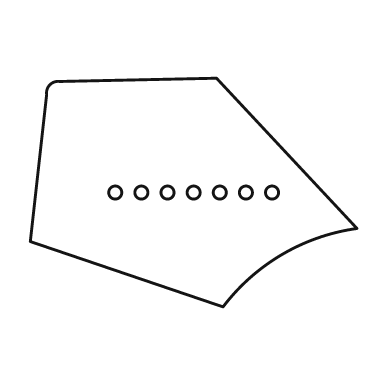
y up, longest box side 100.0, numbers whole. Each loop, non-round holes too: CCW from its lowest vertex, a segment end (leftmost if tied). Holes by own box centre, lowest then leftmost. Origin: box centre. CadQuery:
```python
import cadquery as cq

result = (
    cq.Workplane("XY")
    .moveTo(9.0, -35.0)
    .threePointArc((27.0, -19.0), (50.0, -11.0))
    .lineTo(7.0, 35.0)
    .lineTo(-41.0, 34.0)
    .threePointArc((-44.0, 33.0), (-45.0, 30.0))
    .lineTo(-50.0, -15.0)
    .close()
    .moveTo(-24.0, 0.0)
    .circle(2.0)
    .moveTo(-16.0, 0.0)
    .circle(2.0)
    .moveTo(-8.0, 0.0)
    .circle(2.0)
    .moveTo(0.0, 0.0)
    .circle(2.0)
    .moveTo(8.0, 0.0)
    .circle(2.0)
    .moveTo(16.0, 0.0)
    .circle(2.0)
    .moveTo(24.0, 0.0)
    .circle(2.0)
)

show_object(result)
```